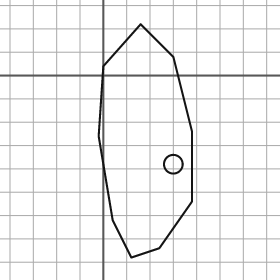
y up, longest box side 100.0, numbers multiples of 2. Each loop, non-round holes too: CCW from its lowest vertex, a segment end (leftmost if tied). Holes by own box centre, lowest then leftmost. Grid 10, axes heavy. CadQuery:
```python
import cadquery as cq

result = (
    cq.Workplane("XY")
    .moveTo(12.0, -78.0)
    .lineTo(24.0, -74.0)
    .lineTo(38.0, -54.0)
    .lineTo(38.0, -24.0)
    .lineTo(30.0, 8.0)
    .lineTo(16.0, 22.0)
    .lineTo(0.0, 4.0)
    .lineTo(-2.0, -26.0)
    .lineTo(4.0, -62.0)
    .close()
    .moveTo(30.0, -38.0)
    .circle(4.0)
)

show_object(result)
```